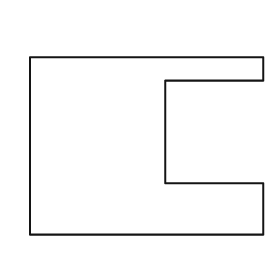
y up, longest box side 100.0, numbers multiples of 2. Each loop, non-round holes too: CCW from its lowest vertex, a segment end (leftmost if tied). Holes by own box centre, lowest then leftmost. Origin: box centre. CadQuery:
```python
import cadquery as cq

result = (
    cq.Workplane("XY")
    .moveTo(-50.0, -38.0)
    .lineTo(50.0, -38.0)
    .lineTo(50.0, -16.0)
    .lineTo(8.0, -16.0)
    .lineTo(8.0, 28.0)
    .lineTo(50.0, 28.0)
    .lineTo(50.0, 38.0)
    .lineTo(-50.0, 38.0)
    .close()
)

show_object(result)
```